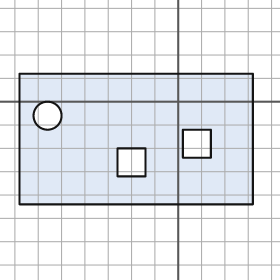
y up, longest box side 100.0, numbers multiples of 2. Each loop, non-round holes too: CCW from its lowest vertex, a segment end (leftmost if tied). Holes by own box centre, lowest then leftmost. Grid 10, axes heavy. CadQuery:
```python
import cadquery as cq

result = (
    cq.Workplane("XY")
    .moveTo(-68.0, -44.0)
    .lineTo(32.0, -44.0)
    .lineTo(32.0, 12.0)
    .lineTo(-68.0, 12.0)
    .close()
    .moveTo(-26.0, -32.0)
    .lineTo(-14.0, -32.0)
    .lineTo(-14.0, -20.0)
    .lineTo(-26.0, -20.0)
    .close()
    .moveTo(2.0, -24.0)
    .lineTo(14.0, -24.0)
    .lineTo(14.0, -12.0)
    .lineTo(2.0, -12.0)
    .close()
    .moveTo(-56.0, -6.0)
    .circle(6.0)
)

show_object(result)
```